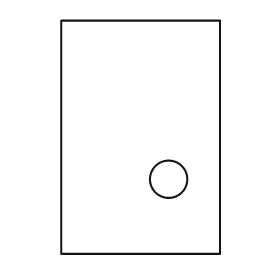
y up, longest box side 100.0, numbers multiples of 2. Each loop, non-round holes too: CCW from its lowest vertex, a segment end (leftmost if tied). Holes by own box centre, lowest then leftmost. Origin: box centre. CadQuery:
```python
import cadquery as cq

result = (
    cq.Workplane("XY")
    .moveTo(-34.0, -50.0)
    .lineTo(34.0, -50.0)
    .lineTo(34.0, 50.0)
    .lineTo(-34.0, 50.0)
    .close()
    .moveTo(12.0, -18.0)
    .circle(8.0)
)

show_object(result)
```